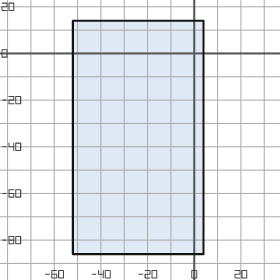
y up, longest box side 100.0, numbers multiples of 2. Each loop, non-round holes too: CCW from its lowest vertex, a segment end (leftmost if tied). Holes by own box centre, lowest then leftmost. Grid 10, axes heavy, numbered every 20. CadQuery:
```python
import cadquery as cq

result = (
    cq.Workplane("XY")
    .moveTo(-52.0, -86.0)
    .lineTo(4.0, -86.0)
    .lineTo(4.0, 14.0)
    .lineTo(-52.0, 14.0)
    .close()
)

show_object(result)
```